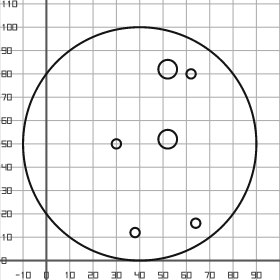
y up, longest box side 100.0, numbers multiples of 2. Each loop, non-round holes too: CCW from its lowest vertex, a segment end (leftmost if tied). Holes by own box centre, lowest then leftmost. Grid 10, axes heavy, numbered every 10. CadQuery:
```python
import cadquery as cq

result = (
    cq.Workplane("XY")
    .moveTo(40.0, 50.0)
    .circle(50.0)
    .moveTo(38.0, 12.0)
    .circle(2.0)
    .moveTo(64.0, 16.0)
    .circle(2.0)
    .moveTo(30.0, 50.0)
    .circle(2.0)
    .moveTo(52.0, 52.0)
    .circle(4.0)
    .moveTo(62.0, 80.0)
    .circle(2.0)
    .moveTo(52.0, 82.0)
    .circle(4.0)
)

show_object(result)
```